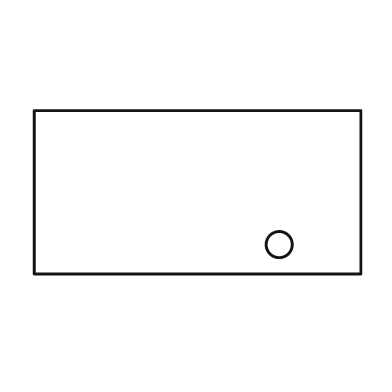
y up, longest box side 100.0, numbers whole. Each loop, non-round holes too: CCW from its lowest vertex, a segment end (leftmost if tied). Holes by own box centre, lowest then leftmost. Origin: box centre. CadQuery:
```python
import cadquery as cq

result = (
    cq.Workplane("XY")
    .moveTo(-50.0, -25.0)
    .lineTo(50.0, -25.0)
    .lineTo(50.0, 25.0)
    .lineTo(-50.0, 25.0)
    .close()
    .moveTo(25.0, -16.0)
    .circle(4.0)
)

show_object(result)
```